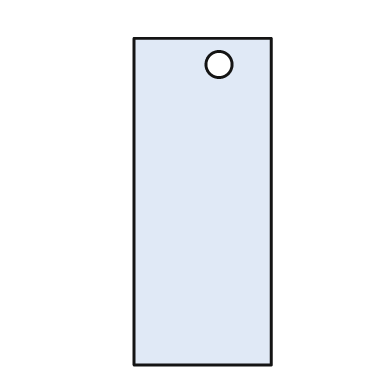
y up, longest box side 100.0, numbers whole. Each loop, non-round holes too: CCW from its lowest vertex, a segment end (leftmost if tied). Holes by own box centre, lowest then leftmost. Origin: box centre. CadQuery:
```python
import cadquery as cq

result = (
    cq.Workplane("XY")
    .moveTo(-21.0, -50.0)
    .lineTo(21.0, -50.0)
    .lineTo(21.0, 50.0)
    .lineTo(-21.0, 50.0)
    .close()
    .moveTo(5.0, 42.0)
    .circle(4.0)
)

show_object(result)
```